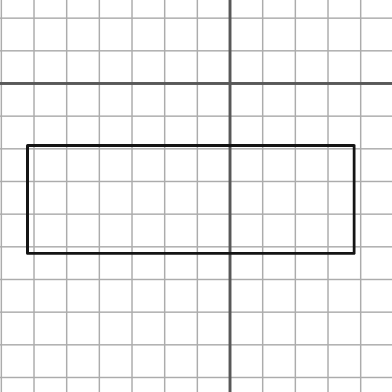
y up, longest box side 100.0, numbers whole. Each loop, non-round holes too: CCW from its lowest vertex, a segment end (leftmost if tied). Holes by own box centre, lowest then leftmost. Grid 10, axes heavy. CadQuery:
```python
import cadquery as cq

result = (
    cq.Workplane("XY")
    .moveTo(-62.0, -52.0)
    .lineTo(38.0, -52.0)
    .lineTo(38.0, -19.0)
    .lineTo(-62.0, -19.0)
    .close()
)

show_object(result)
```